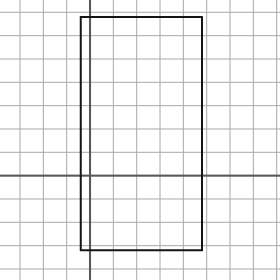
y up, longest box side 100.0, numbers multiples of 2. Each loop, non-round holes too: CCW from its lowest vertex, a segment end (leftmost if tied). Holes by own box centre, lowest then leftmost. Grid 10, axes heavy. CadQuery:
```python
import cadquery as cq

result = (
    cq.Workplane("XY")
    .moveTo(-4.0, -32.0)
    .lineTo(48.0, -32.0)
    .lineTo(48.0, 68.0)
    .lineTo(-4.0, 68.0)
    .close()
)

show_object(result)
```